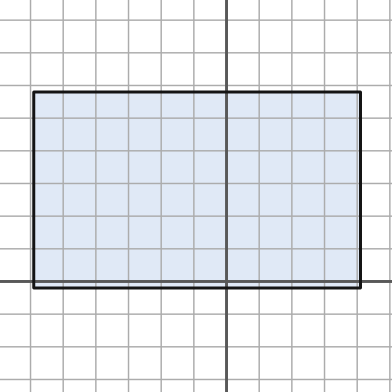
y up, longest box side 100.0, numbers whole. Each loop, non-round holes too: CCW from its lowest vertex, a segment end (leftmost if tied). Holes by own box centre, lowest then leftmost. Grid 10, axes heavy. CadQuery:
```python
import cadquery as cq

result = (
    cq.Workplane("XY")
    .moveTo(-59.0, -2.0)
    .lineTo(41.0, -2.0)
    .lineTo(41.0, 58.0)
    .lineTo(-59.0, 58.0)
    .close()
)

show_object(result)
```